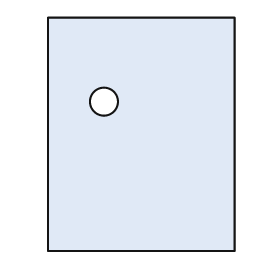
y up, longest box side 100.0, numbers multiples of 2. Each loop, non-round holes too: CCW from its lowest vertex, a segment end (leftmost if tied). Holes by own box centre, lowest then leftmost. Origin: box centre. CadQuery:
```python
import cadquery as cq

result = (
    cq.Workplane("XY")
    .moveTo(-40.0, -50.0)
    .lineTo(40.0, -50.0)
    .lineTo(40.0, 50.0)
    .lineTo(-40.0, 50.0)
    .close()
    .moveTo(-16.0, 14.0)
    .circle(6.0)
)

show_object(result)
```